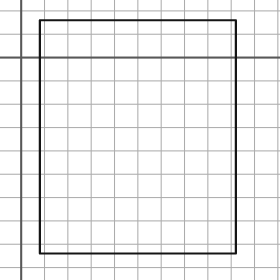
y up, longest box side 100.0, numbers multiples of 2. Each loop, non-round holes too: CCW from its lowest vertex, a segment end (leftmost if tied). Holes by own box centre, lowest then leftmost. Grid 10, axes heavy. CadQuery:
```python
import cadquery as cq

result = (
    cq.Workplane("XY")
    .moveTo(8.0, -84.0)
    .lineTo(92.0, -84.0)
    .lineTo(92.0, 16.0)
    .lineTo(8.0, 16.0)
    .close()
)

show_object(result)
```